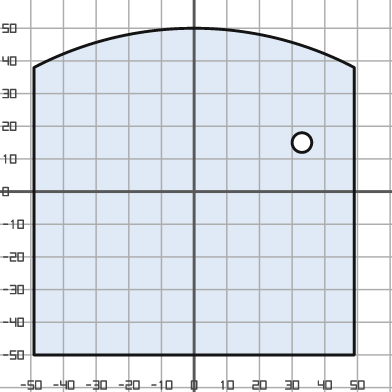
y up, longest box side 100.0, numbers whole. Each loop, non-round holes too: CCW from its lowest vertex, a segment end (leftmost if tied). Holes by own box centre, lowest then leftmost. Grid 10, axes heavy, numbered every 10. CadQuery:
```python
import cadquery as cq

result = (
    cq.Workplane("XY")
    .moveTo(-49.0, -50.0)
    .lineTo(49.0, -50.0)
    .lineTo(49.0, 38.0)
    .threePointArc((0.0, 50.0), (-49.0, 38.0))
    .close()
    .moveTo(33.0, 15.0)
    .circle(3.0)
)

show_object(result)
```